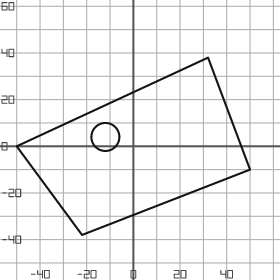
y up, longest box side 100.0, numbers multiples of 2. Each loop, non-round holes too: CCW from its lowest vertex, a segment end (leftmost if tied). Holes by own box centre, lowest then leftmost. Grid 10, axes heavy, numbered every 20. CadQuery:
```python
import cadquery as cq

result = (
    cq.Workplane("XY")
    .moveTo(-22.0, -38.0)
    .lineTo(50.0, -10.0)
    .lineTo(32.0, 38.0)
    .lineTo(-50.0, 0.0)
    .close()
    .moveTo(-12.0, 4.0)
    .circle(6.0)
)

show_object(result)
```